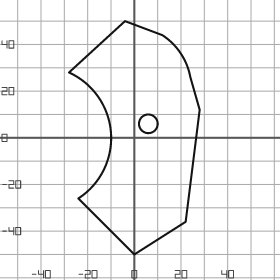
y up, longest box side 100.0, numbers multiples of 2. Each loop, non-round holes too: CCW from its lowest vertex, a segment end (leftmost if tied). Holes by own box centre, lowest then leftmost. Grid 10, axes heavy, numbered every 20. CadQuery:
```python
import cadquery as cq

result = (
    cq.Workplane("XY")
    .moveTo(0.0, -50.0)
    .lineTo(22.0, -36.0)
    .lineTo(28.0, 12.0)
    .lineTo(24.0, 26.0)
    .threePointArc((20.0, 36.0), (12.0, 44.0))
    .lineTo(-4.0, 50.0)
    .lineTo(-28.0, 28.0)
    .threePointArc((-10.0, 2.0), (-24.0, -26.0))
    .close()
    .moveTo(6.0, 6.0)
    .circle(4.0)
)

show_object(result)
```